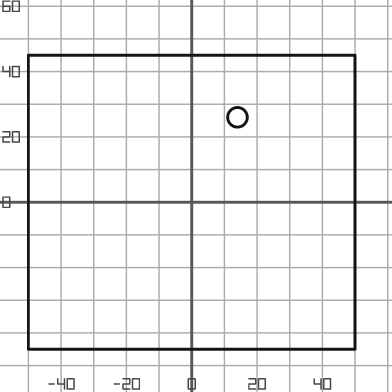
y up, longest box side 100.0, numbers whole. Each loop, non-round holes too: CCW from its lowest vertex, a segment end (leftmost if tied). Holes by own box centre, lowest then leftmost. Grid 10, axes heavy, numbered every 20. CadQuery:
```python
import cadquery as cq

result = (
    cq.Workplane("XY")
    .moveTo(-50.0, -45.0)
    .lineTo(50.0, -45.0)
    .lineTo(50.0, 45.0)
    .lineTo(-50.0, 45.0)
    .close()
    .moveTo(14.0, 26.0)
    .circle(3.0)
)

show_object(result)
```